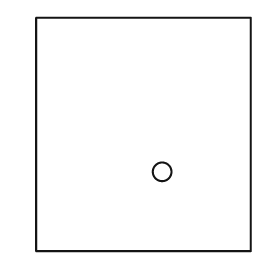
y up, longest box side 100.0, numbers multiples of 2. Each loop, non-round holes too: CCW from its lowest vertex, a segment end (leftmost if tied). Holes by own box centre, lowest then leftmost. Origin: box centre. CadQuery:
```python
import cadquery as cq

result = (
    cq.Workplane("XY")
    .moveTo(-46.0, -50.0)
    .lineTo(46.0, -50.0)
    .lineTo(46.0, 50.0)
    .lineTo(-46.0, 50.0)
    .close()
    .moveTo(8.0, -16.0)
    .circle(4.0)
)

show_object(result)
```